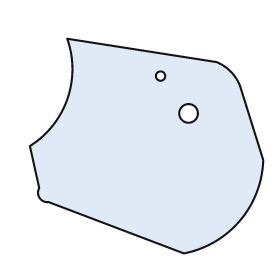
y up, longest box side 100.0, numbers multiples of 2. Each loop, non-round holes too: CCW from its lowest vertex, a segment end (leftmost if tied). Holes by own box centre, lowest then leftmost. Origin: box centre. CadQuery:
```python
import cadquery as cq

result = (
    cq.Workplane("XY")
    .moveTo(16.0, -46.0)
    .threePointArc((40.0, -32.0), (50.0, -6.0))
    .lineTo(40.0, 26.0)
    .threePointArc((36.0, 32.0), (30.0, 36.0))
    .lineTo(-34.0, 46.0)
    .threePointArc((-34.0, 20.0), (-50.0, 0.0))
    .lineTo(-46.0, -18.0)
    .threePointArc((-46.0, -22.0), (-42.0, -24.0))
    .close()
    .moveTo(18.0, 14.0)
    .circle(4.0)
    .moveTo(6.0, 30.0)
    .circle(2.0)
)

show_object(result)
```